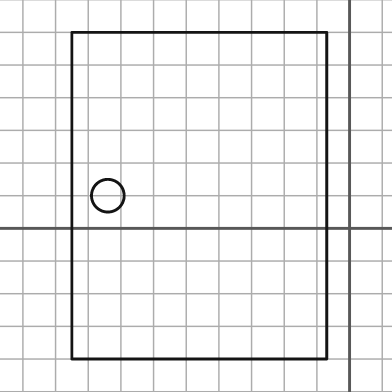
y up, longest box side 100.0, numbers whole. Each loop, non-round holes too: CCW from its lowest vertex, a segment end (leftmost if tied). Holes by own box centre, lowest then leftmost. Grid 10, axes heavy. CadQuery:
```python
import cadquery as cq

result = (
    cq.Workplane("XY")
    .moveTo(-85.0, -40.0)
    .lineTo(-7.0, -40.0)
    .lineTo(-7.0, 60.0)
    .lineTo(-85.0, 60.0)
    .close()
    .moveTo(-74.0, 10.0)
    .circle(5.0)
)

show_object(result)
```